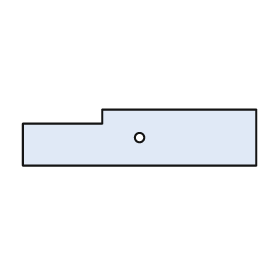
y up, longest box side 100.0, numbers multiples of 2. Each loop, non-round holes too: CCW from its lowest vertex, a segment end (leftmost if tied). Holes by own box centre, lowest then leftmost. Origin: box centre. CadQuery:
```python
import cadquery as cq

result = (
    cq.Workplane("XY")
    .moveTo(-50.0, -12.0)
    .lineTo(50.0, -12.0)
    .lineTo(50.0, 12.0)
    .lineTo(-16.0, 12.0)
    .lineTo(-16.0, 6.0)
    .lineTo(-50.0, 6.0)
    .close()
    .moveTo(0.0, 0.0)
    .circle(2.0)
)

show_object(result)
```